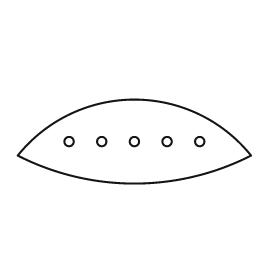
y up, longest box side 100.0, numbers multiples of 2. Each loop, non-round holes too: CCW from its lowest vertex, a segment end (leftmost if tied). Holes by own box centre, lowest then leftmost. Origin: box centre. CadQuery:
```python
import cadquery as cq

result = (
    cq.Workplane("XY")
    .moveTo(-50.0, -6.0)
    .threePointArc((0.0, -18.0), (50.0, -6.0))
    .threePointArc((0.0, 18.0), (-50.0, -6.0))
    .close()
    .moveTo(-28.0, 0.0)
    .circle(2.0)
    .moveTo(-14.0, 0.0)
    .circle(2.0)
    .moveTo(0.0, 0.0)
    .circle(2.0)
    .moveTo(14.0, 0.0)
    .circle(2.0)
    .moveTo(28.0, 0.0)
    .circle(2.0)
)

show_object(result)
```